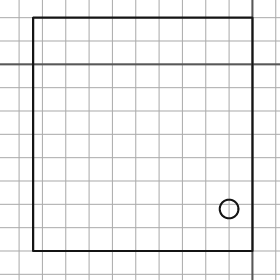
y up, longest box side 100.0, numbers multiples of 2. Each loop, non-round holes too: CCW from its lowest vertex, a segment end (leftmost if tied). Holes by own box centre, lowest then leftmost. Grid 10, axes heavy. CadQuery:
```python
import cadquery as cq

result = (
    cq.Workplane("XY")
    .moveTo(-94.0, -80.0)
    .lineTo(0.0, -80.0)
    .lineTo(0.0, 20.0)
    .lineTo(-94.0, 20.0)
    .close()
    .moveTo(-10.0, -62.0)
    .circle(4.0)
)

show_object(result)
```